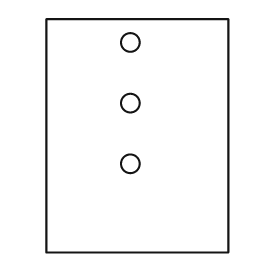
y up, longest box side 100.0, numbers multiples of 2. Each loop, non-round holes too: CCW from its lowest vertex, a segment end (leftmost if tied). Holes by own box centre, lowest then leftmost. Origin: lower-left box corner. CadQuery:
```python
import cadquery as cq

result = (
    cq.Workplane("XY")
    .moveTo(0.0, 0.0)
    .lineTo(78.0, 0.0)
    .lineTo(78.0, 100.0)
    .lineTo(0.0, 100.0)
    .close()
    .moveTo(36.0, 38.0)
    .circle(4.0)
    .moveTo(36.0, 64.0)
    .circle(4.0)
    .moveTo(36.0, 90.0)
    .circle(4.0)
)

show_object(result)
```